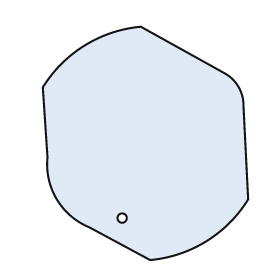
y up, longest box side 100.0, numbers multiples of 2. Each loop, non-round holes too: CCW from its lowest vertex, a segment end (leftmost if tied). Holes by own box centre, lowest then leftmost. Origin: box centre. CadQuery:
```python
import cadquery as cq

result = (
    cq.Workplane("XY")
    .moveTo(2.0, -50.0)
    .threePointArc((26.0, -42.0), (44.0, -24.0))
    .lineTo(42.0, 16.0)
    .threePointArc((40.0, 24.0), (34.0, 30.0))
    .lineTo(-2.0, 50.0)
    .threePointArc((-26.0, 42.0), (-44.0, 24.0))
    .lineTo(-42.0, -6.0)
    .threePointArc((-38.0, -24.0), (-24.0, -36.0))
    .close()
    .moveTo(-10.0, -32.0)
    .circle(2.0)
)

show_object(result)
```